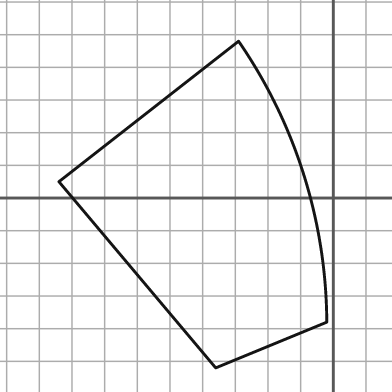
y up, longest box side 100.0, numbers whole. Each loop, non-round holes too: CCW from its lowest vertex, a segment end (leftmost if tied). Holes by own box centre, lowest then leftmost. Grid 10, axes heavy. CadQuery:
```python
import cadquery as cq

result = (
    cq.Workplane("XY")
    .moveTo(-36.0, -52.0)
    .lineTo(-2.0, -38.0)
    .threePointArc((-9.0, 7.0), (-29.0, 48.0))
    .lineTo(-84.0, 5.0)
    .close()
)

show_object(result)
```